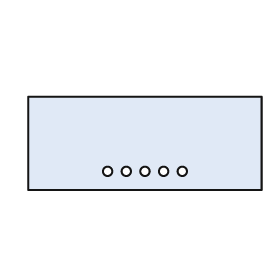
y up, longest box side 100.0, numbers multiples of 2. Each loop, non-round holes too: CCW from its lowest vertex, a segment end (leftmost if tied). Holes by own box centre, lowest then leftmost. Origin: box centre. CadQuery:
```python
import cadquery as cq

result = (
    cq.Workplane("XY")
    .moveTo(-50.0, -20.0)
    .lineTo(50.0, -20.0)
    .lineTo(50.0, 20.0)
    .lineTo(-50.0, 20.0)
    .close()
    .moveTo(-16.0, -12.0)
    .circle(2.0)
    .moveTo(-8.0, -12.0)
    .circle(2.0)
    .moveTo(0.0, -12.0)
    .circle(2.0)
    .moveTo(8.0, -12.0)
    .circle(2.0)
    .moveTo(16.0, -12.0)
    .circle(2.0)
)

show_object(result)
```